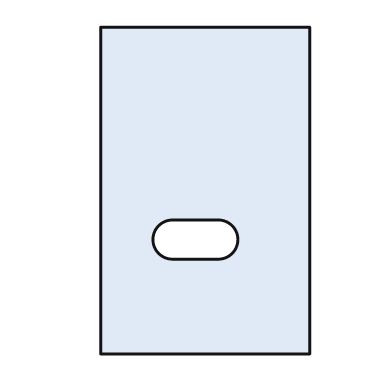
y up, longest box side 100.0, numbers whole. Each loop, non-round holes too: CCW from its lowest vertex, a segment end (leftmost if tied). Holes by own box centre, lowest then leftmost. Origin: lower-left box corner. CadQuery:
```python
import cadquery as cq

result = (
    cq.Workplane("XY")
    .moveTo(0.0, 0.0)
    .lineTo(64.0, 0.0)
    .lineTo(64.0, 100.0)
    .lineTo(0.0, 100.0)
    .close()
    .moveTo(22.0, 29.0)
    .lineTo(36.0, 29.0)
    .threePointArc((42.0, 35.0), (36.0, 41.0))
    .lineTo(22.0, 41.0)
    .threePointArc((16.0, 35.0), (22.0, 29.0))
    .close()
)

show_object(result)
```